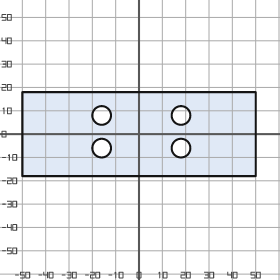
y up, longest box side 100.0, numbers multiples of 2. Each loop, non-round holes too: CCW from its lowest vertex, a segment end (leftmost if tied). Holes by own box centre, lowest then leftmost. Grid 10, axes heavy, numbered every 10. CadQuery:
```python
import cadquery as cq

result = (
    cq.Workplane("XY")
    .moveTo(-50.0, -18.0)
    .lineTo(50.0, -18.0)
    .lineTo(50.0, 18.0)
    .lineTo(-50.0, 18.0)
    .close()
    .moveTo(-16.0, -6.0)
    .circle(4.0)
    .moveTo(18.0, -6.0)
    .circle(4.0)
    .moveTo(-16.0, 8.0)
    .circle(4.0)
    .moveTo(18.0, 8.0)
    .circle(4.0)
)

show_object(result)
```